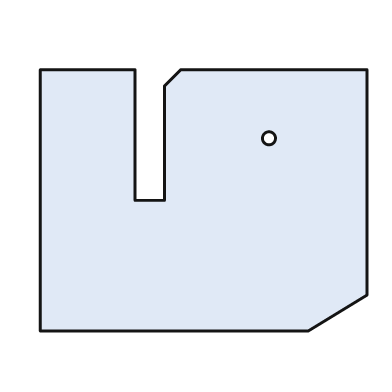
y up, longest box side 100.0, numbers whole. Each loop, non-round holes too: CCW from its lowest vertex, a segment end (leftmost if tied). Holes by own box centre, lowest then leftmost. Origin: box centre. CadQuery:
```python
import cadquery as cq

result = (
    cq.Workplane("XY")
    .moveTo(-50.0, -40.0)
    .lineTo(32.0, -40.0)
    .lineTo(50.0, -29.0)
    .lineTo(50.0, 40.0)
    .lineTo(-7.0, 40.0)
    .lineTo(-12.0, 35.0)
    .lineTo(-12.0, 0.0)
    .lineTo(-21.0, 0.0)
    .lineTo(-21.0, 40.0)
    .lineTo(-50.0, 40.0)
    .close()
    .moveTo(20.0, 19.0)
    .circle(2.0)
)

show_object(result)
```